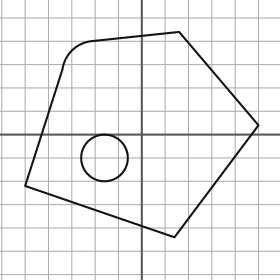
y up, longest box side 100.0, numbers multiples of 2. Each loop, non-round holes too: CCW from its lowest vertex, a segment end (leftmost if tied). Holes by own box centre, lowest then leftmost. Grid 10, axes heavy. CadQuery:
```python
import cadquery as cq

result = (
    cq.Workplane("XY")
    .moveTo(14.0, -44.0)
    .lineTo(50.0, 4.0)
    .lineTo(16.0, 44.0)
    .lineTo(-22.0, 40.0)
    .threePointArc((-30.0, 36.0), (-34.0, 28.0))
    .lineTo(-50.0, -22.0)
    .close()
    .moveTo(-16.0, -10.0)
    .circle(10.0)
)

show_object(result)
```